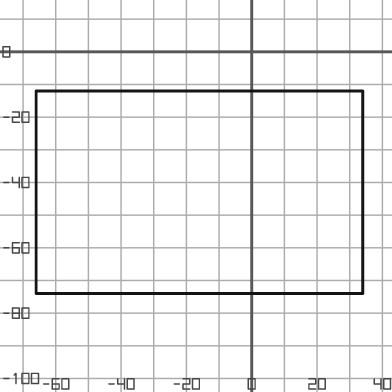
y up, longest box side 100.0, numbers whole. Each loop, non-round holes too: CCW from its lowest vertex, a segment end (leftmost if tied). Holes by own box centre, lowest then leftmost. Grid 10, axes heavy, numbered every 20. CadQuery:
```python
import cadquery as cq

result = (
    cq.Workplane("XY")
    .moveTo(-66.0, -74.0)
    .lineTo(34.0, -74.0)
    .lineTo(34.0, -12.0)
    .lineTo(-66.0, -12.0)
    .close()
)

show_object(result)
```